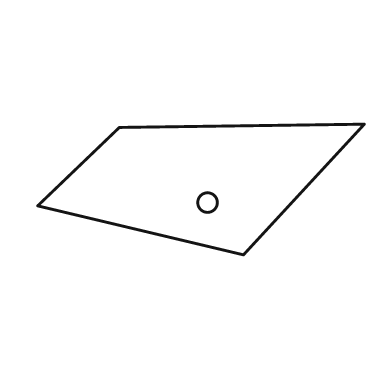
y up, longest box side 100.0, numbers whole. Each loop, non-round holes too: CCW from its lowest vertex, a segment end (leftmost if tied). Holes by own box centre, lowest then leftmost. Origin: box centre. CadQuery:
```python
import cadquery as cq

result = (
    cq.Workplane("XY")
    .moveTo(13.0, -20.0)
    .lineTo(50.0, 20.0)
    .lineTo(-25.0, 19.0)
    .lineTo(-50.0, -5.0)
    .close()
    .moveTo(2.0, -4.0)
    .circle(3.0)
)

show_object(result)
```